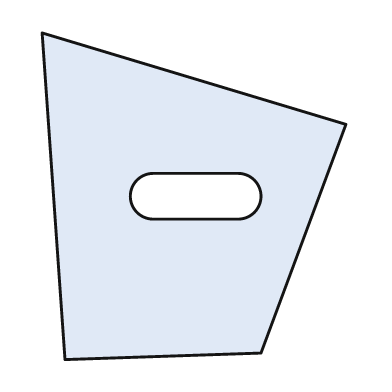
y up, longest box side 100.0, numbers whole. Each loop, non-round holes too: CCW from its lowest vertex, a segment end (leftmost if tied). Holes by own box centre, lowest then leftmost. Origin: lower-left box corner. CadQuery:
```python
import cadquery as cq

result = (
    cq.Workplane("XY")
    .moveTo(7.0, 0.0)
    .lineTo(67.0, 2.0)
    .lineTo(93.0, 72.0)
    .lineTo(0.0, 100.0)
    .close()
    .moveTo(34.0, 43.0)
    .lineTo(60.0, 43.0)
    .threePointArc((67.0, 50.0), (60.0, 57.0))
    .lineTo(34.0, 57.0)
    .threePointArc((27.0, 50.0), (34.0, 43.0))
    .close()
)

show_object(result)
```